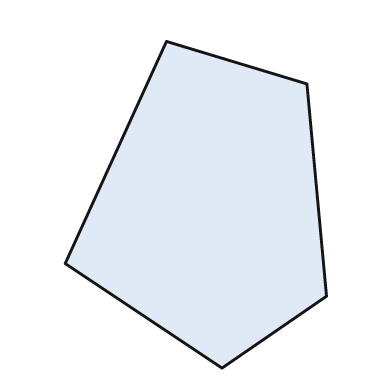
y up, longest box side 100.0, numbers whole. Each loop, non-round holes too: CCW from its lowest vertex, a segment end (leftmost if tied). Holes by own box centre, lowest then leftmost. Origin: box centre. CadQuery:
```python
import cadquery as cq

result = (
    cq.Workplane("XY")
    .moveTo(8.0, -50.0)
    .lineTo(40.0, -28.0)
    .lineTo(34.0, 37.0)
    .lineTo(-9.0, 50.0)
    .lineTo(-40.0, -18.0)
    .close()
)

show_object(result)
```